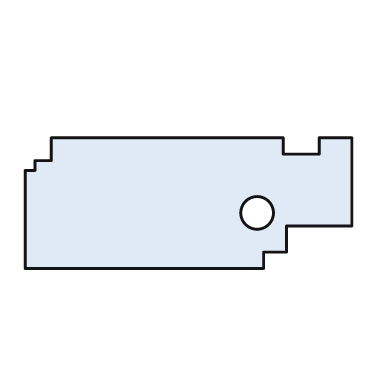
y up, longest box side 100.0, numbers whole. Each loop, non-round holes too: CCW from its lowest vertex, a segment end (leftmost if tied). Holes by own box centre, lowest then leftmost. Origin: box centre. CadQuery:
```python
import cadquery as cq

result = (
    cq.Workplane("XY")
    .moveTo(-50.0, -20.0)
    .lineTo(23.0, -20.0)
    .lineTo(23.0, -15.0)
    .lineTo(30.0, -15.0)
    .lineTo(30.0, -7.0)
    .lineTo(50.0, -7.0)
    .lineTo(50.0, 20.0)
    .lineTo(40.0, 20.0)
    .lineTo(40.0, 15.0)
    .lineTo(29.0, 15.0)
    .lineTo(29.0, 20.0)
    .lineTo(-42.0, 20.0)
    .lineTo(-42.0, 13.0)
    .lineTo(-47.0, 13.0)
    .lineTo(-47.0, 10.0)
    .lineTo(-50.0, 10.0)
    .close()
    .moveTo(21.0, -3.0)
    .circle(5.0)
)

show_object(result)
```